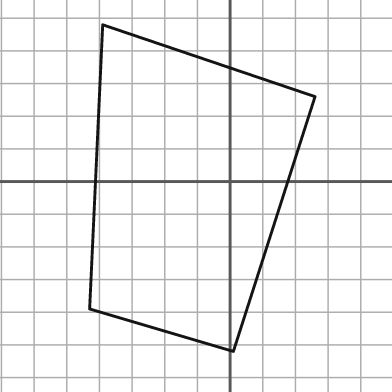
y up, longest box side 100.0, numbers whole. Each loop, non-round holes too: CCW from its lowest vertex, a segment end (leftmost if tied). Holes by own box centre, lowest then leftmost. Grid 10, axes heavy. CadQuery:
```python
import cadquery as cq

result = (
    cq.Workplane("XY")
    .moveTo(1.0, -52.0)
    .lineTo(26.0, 26.0)
    .lineTo(-39.0, 48.0)
    .lineTo(-43.0, -39.0)
    .close()
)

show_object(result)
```